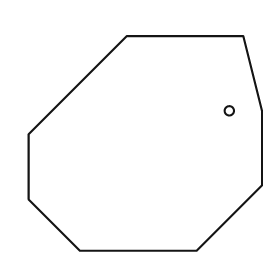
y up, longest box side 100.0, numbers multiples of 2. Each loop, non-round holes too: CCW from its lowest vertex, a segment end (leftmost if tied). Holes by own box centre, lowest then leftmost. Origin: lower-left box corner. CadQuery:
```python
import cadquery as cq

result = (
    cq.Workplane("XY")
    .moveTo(22.0, 0.0)
    .lineTo(72.0, 0.0)
    .lineTo(100.0, 28.0)
    .lineTo(100.0, 60.0)
    .lineTo(92.0, 92.0)
    .lineTo(42.0, 92.0)
    .lineTo(0.0, 50.0)
    .lineTo(0.0, 22.0)
    .close()
    .moveTo(86.0, 60.0)
    .circle(2.0)
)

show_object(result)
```